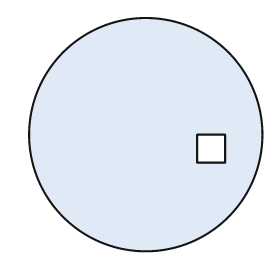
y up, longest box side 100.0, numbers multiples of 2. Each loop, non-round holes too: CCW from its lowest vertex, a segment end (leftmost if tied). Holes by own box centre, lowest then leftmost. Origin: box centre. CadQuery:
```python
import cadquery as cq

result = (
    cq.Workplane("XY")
    .moveTo(0.0, 0.0)
    .circle(50.0)
    .moveTo(22.0, -12.0)
    .lineTo(34.0, -12.0)
    .lineTo(34.0, 0.0)
    .lineTo(22.0, 0.0)
    .close()
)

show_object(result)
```